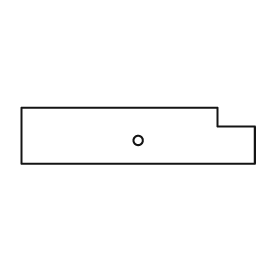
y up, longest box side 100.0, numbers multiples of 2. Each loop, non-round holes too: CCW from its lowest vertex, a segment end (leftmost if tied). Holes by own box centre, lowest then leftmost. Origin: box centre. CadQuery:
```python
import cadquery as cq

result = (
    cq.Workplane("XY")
    .moveTo(-50.0, -12.0)
    .lineTo(50.0, -12.0)
    .lineTo(50.0, 4.0)
    .lineTo(34.0, 4.0)
    .lineTo(34.0, 12.0)
    .lineTo(-50.0, 12.0)
    .close()
    .moveTo(0.0, -2.0)
    .circle(2.0)
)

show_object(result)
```